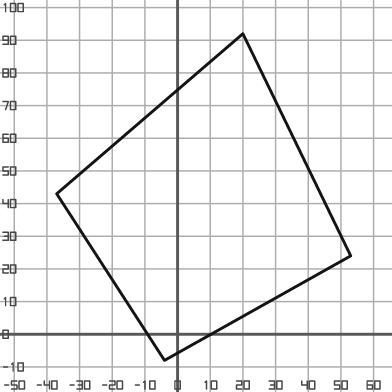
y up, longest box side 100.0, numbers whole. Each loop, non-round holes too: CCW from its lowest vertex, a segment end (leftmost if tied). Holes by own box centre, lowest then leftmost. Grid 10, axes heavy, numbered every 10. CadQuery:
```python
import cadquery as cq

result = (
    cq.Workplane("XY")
    .moveTo(-4.0, -8.0)
    .lineTo(53.0, 24.0)
    .lineTo(20.0, 92.0)
    .lineTo(-37.0, 43.0)
    .close()
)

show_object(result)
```